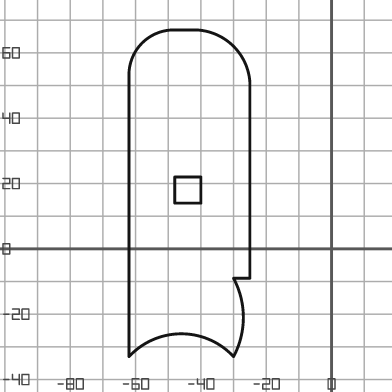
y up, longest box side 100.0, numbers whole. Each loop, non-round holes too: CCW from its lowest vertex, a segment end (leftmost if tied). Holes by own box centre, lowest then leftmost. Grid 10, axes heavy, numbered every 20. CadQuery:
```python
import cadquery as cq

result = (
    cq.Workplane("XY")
    .moveTo(-62.0, -33.0)
    .threePointArc((-46.0, -26.0), (-30.0, -33.0))
    .threePointArc((-27.0, -21.0), (-30.0, -9.0))
    .lineTo(-25.0, -9.0)
    .lineTo(-25.0, 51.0)
    .threePointArc((-30.0, 62.0), (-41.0, 67.0))
    .lineTo(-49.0, 67.0)
    .threePointArc((-58.0, 63.0), (-62.0, 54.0))
    .close()
    .moveTo(-48.0, 14.0)
    .lineTo(-40.0, 14.0)
    .lineTo(-40.0, 22.0)
    .lineTo(-48.0, 22.0)
    .close()
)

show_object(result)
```